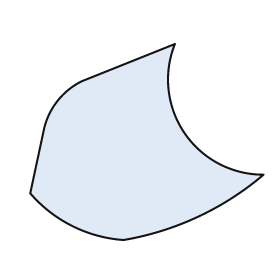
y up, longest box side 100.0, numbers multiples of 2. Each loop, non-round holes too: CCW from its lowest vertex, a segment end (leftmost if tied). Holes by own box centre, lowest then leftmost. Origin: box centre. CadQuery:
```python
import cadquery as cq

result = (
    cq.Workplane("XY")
    .moveTo(-10.0, -42.0)
    .threePointArc((22.0, -32.0), (50.0, -14.0))
    .threePointArc((16.0, 4.0), (12.0, 42.0))
    .lineTo(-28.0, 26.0)
    .threePointArc((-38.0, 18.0), (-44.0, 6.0))
    .lineTo(-50.0, -22.0)
    .threePointArc((-32.0, -36.0), (-10.0, -42.0))
    .close()
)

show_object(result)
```